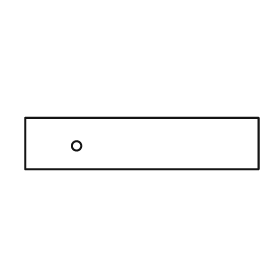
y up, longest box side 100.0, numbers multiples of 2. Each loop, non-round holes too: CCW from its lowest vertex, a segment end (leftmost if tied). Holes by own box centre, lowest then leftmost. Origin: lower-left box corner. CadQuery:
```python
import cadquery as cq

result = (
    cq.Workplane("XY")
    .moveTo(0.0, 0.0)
    .lineTo(100.0, 0.0)
    .lineTo(100.0, 22.0)
    .lineTo(0.0, 22.0)
    .close()
    .moveTo(22.0, 10.0)
    .circle(2.0)
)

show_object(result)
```